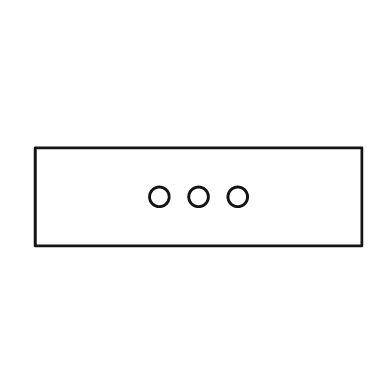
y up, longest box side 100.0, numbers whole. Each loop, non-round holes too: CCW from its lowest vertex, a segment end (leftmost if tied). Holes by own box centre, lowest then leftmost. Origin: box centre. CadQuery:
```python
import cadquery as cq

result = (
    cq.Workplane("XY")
    .moveTo(-50.0, -15.0)
    .lineTo(50.0, -15.0)
    .lineTo(50.0, 15.0)
    .lineTo(-50.0, 15.0)
    .close()
    .moveTo(-12.0, 0.0)
    .circle(3.0)
    .moveTo(0.0, 0.0)
    .circle(3.0)
    .moveTo(12.0, 0.0)
    .circle(3.0)
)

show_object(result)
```